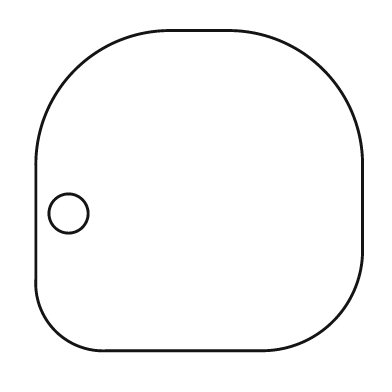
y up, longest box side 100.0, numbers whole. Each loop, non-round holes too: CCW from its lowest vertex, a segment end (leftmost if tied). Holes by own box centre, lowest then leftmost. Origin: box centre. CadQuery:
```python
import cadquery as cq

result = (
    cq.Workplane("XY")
    .moveTo(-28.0, -49.0)
    .lineTo(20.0, -49.0)
    .threePointArc((41.0, -40.0), (50.0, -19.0))
    .lineTo(50.0, 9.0)
    .threePointArc((38.0, 37.0), (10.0, 49.0))
    .lineTo(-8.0, 49.0)
    .threePointArc((-38.0, 37.0), (-50.0, 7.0))
    .lineTo(-50.0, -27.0)
    .threePointArc((-44.0, -43.0), (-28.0, -49.0))
    .close()
    .moveTo(-40.0, -7.0)
    .circle(6.0)
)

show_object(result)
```